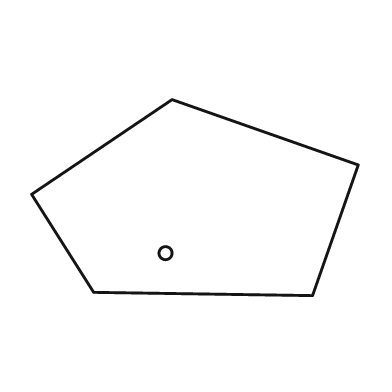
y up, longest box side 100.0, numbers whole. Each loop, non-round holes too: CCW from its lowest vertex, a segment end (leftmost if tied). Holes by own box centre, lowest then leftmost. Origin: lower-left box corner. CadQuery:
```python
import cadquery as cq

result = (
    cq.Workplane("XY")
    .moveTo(86.0, 0.0)
    .lineTo(100.0, 40.0)
    .lineTo(43.0, 60.0)
    .lineTo(0.0, 31.0)
    .lineTo(19.0, 1.0)
    .close()
    .moveTo(41.0, 13.0)
    .circle(2.0)
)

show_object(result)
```